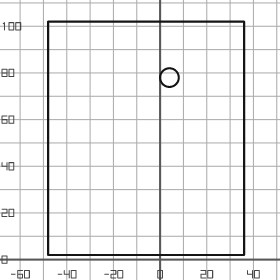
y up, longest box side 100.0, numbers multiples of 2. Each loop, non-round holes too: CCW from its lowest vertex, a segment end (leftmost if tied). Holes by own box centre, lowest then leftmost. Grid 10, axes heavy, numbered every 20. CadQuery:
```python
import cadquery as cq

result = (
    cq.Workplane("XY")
    .moveTo(-48.0, 2.0)
    .lineTo(36.0, 2.0)
    .lineTo(36.0, 102.0)
    .lineTo(-48.0, 102.0)
    .close()
    .moveTo(4.0, 78.0)
    .circle(4.0)
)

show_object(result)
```